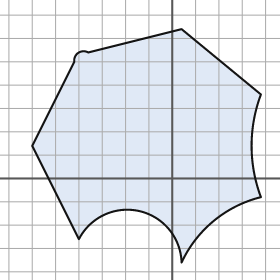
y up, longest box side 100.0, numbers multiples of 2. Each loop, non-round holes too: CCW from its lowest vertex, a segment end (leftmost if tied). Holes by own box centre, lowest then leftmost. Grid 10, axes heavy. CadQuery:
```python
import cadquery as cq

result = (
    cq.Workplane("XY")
    .moveTo(4.0, -36.0)
    .threePointArc((18.0, -18.0), (38.0, -8.0))
    .threePointArc((34.0, 14.0), (38.0, 36.0))
    .lineTo(4.0, 64.0)
    .lineTo(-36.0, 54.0)
    .threePointArc((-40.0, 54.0), (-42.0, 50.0))
    .lineTo(-60.0, 14.0)
    .lineTo(-40.0, -26.0)
    .threePointArc((-14.0, -14.0), (4.0, -36.0))
    .close()
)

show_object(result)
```